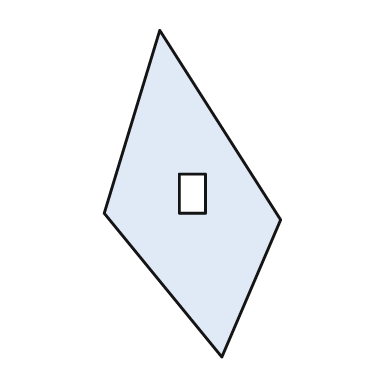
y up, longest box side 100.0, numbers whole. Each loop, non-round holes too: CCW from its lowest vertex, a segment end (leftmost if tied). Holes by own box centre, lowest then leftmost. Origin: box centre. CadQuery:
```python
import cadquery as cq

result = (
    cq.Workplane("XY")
    .moveTo(9.0, -50.0)
    .lineTo(27.0, -8.0)
    .lineTo(-10.0, 50.0)
    .lineTo(-27.0, -6.0)
    .close()
    .moveTo(-4.0, -6.0)
    .lineTo(4.0, -6.0)
    .lineTo(4.0, 6.0)
    .lineTo(-4.0, 6.0)
    .close()
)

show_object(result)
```